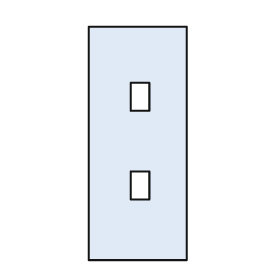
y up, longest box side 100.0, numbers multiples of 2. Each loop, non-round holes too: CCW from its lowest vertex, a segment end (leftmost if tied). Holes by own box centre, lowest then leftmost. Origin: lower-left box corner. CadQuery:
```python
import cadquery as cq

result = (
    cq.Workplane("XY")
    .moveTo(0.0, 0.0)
    .lineTo(42.0, 0.0)
    .lineTo(42.0, 100.0)
    .lineTo(0.0, 100.0)
    .close()
    .moveTo(18.0, 26.0)
    .lineTo(26.0, 26.0)
    .lineTo(26.0, 38.0)
    .lineTo(18.0, 38.0)
    .close()
    .moveTo(18.0, 64.0)
    .lineTo(26.0, 64.0)
    .lineTo(26.0, 76.0)
    .lineTo(18.0, 76.0)
    .close()
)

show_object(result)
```